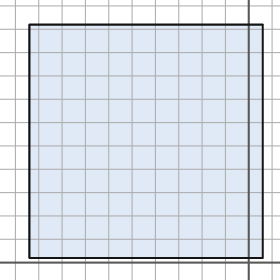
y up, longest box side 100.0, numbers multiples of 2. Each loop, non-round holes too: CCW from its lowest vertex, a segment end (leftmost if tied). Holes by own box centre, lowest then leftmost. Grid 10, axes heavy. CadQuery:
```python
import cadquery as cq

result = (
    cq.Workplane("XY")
    .moveTo(-94.0, 2.0)
    .lineTo(6.0, 2.0)
    .lineTo(6.0, 102.0)
    .lineTo(-94.0, 102.0)
    .close()
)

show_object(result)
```